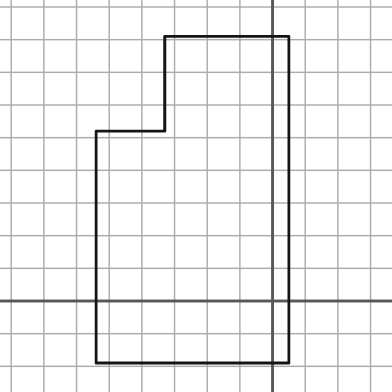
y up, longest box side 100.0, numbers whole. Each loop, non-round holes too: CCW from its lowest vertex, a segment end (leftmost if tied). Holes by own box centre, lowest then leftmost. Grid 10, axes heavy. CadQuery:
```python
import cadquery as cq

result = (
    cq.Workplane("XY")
    .moveTo(-54.0, -19.0)
    .lineTo(5.0, -19.0)
    .lineTo(5.0, 81.0)
    .lineTo(-33.0, 81.0)
    .lineTo(-33.0, 52.0)
    .lineTo(-54.0, 52.0)
    .close()
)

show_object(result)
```